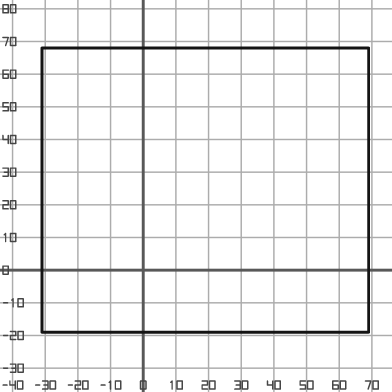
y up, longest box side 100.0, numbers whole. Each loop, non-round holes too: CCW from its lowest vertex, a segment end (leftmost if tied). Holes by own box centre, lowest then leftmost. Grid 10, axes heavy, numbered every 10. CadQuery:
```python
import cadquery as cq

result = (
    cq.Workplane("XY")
    .moveTo(-31.0, -19.0)
    .lineTo(69.0, -19.0)
    .lineTo(69.0, 68.0)
    .lineTo(-31.0, 68.0)
    .close()
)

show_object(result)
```